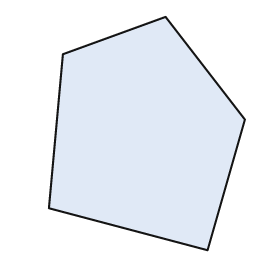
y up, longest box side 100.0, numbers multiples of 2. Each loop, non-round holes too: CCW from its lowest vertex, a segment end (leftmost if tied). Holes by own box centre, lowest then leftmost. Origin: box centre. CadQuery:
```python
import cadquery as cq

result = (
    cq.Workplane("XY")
    .moveTo(26.0, -50.0)
    .lineTo(42.0, 6.0)
    .lineTo(8.0, 50.0)
    .lineTo(-36.0, 34.0)
    .lineTo(-42.0, -32.0)
    .close()
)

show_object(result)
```